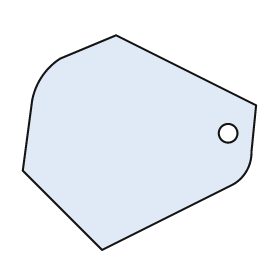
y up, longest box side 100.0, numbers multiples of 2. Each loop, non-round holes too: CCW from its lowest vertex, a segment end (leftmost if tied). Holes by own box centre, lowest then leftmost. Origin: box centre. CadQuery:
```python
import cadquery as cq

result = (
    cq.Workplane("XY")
    .moveTo(-16.0, -46.0)
    .lineTo(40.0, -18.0)
    .threePointArc((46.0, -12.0), (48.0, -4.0))
    .lineTo(50.0, 16.0)
    .lineTo(-10.0, 46.0)
    .lineTo(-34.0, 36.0)
    .threePointArc((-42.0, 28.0), (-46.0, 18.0))
    .lineTo(-50.0, -12.0)
    .close()
    .moveTo(38.0, 4.0)
    .circle(4.0)
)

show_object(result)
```